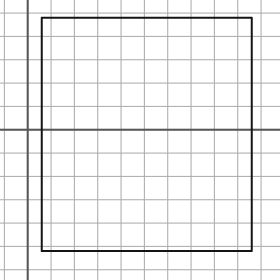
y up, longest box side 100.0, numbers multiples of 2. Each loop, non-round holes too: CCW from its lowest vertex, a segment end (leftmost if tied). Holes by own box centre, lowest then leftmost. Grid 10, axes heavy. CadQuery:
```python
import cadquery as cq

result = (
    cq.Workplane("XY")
    .moveTo(6.0, -52.0)
    .lineTo(96.0, -52.0)
    .lineTo(96.0, 48.0)
    .lineTo(6.0, 48.0)
    .close()
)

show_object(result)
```